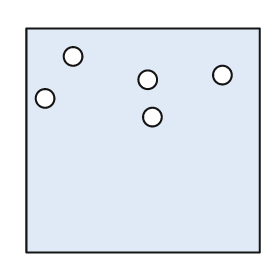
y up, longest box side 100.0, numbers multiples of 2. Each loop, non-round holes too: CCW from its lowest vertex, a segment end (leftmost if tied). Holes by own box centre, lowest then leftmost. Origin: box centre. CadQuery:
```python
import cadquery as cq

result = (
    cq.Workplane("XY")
    .moveTo(-50.0, -48.0)
    .lineTo(50.0, -48.0)
    .lineTo(50.0, 48.0)
    .lineTo(-50.0, 48.0)
    .close()
    .moveTo(4.0, 10.0)
    .circle(4.0)
    .moveTo(-42.0, 18.0)
    .circle(4.0)
    .moveTo(2.0, 26.0)
    .circle(4.0)
    .moveTo(34.0, 28.0)
    .circle(4.0)
    .moveTo(-30.0, 36.0)
    .circle(4.0)
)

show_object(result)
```